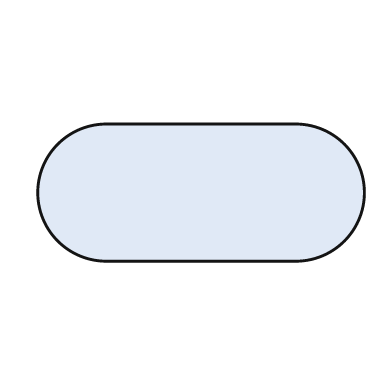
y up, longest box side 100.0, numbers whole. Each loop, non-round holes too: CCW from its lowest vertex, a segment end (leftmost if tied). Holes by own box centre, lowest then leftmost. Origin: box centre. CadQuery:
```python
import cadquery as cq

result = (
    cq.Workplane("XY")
    .moveTo(-29.0, -21.0)
    .lineTo(29.0, -21.0)
    .threePointArc((50.0, 0.0), (29.0, 21.0))
    .lineTo(-29.0, 21.0)
    .threePointArc((-50.0, 0.0), (-29.0, -21.0))
    .close()
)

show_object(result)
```